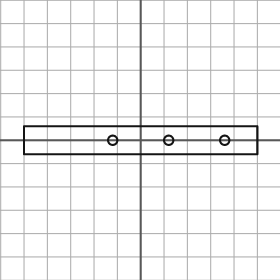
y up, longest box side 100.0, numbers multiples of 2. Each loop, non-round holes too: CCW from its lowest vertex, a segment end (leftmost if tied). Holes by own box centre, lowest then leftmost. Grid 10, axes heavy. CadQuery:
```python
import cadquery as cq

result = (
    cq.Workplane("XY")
    .moveTo(-50.0, -6.0)
    .lineTo(50.0, -6.0)
    .lineTo(50.0, 6.0)
    .lineTo(-50.0, 6.0)
    .close()
    .moveTo(-12.0, 0.0)
    .circle(2.0)
    .moveTo(12.0, 0.0)
    .circle(2.0)
    .moveTo(36.0, 0.0)
    .circle(2.0)
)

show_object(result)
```